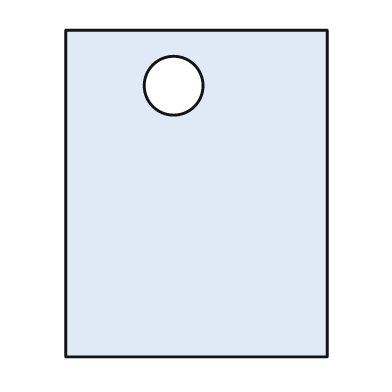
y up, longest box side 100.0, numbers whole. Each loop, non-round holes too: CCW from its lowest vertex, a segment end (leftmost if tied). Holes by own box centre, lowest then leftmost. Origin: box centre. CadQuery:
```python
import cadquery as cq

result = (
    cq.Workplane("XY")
    .moveTo(-40.0, -50.0)
    .lineTo(40.0, -50.0)
    .lineTo(40.0, 50.0)
    .lineTo(-40.0, 50.0)
    .close()
    .moveTo(-7.0, 33.0)
    .circle(9.0)
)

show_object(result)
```